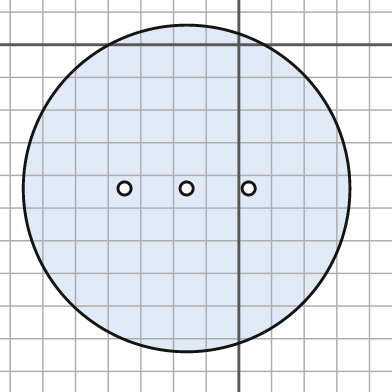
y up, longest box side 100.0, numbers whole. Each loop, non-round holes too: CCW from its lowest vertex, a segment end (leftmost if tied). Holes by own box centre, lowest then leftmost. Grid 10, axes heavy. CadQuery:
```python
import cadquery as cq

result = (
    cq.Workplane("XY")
    .moveTo(-16.0, -44.0)
    .circle(50.0)
    .moveTo(-35.0, -44.0)
    .circle(2.0)
    .moveTo(-16.0, -44.0)
    .circle(2.0)
    .moveTo(3.0, -44.0)
    .circle(2.0)
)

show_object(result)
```